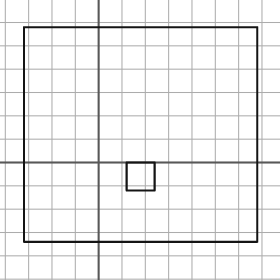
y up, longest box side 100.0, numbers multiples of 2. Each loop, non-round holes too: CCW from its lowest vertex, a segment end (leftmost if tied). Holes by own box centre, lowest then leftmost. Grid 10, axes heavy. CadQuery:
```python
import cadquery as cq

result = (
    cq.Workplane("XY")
    .moveTo(-32.0, -34.0)
    .lineTo(68.0, -34.0)
    .lineTo(68.0, 58.0)
    .lineTo(-32.0, 58.0)
    .close()
    .moveTo(12.0, -12.0)
    .lineTo(24.0, -12.0)
    .lineTo(24.0, 0.0)
    .lineTo(12.0, 0.0)
    .close()
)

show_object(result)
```